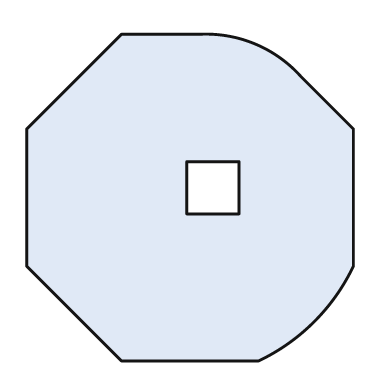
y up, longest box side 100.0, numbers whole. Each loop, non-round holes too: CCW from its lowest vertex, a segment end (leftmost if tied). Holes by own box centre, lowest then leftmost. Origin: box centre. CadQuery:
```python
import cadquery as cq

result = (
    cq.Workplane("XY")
    .moveTo(-21.0, -50.0)
    .lineTo(21.0, -50.0)
    .threePointArc((38.0, -38.0), (50.0, -21.0))
    .lineTo(50.0, 21.0)
    .lineTo(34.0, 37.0)
    .threePointArc((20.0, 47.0), (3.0, 50.0))
    .lineTo(-21.0, 50.0)
    .lineTo(-50.0, 21.0)
    .lineTo(-50.0, -21.0)
    .close()
    .moveTo(-1.0, -5.0)
    .lineTo(15.0, -5.0)
    .lineTo(15.0, 11.0)
    .lineTo(-1.0, 11.0)
    .close()
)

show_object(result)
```